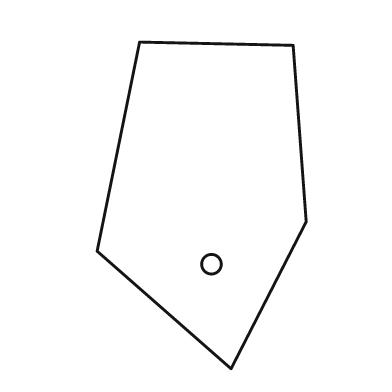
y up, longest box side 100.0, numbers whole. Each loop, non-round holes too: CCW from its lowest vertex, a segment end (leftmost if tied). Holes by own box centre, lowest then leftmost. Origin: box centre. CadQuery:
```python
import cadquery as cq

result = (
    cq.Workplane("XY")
    .moveTo(9.0, -50.0)
    .lineTo(32.0, -5.0)
    .lineTo(28.0, 49.0)
    .lineTo(-19.0, 50.0)
    .lineTo(-32.0, -14.0)
    .close()
    .moveTo(3.0, -18.0)
    .circle(3.0)
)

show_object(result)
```